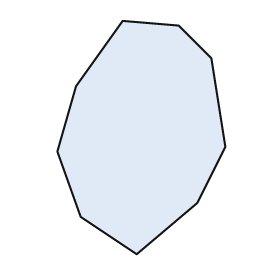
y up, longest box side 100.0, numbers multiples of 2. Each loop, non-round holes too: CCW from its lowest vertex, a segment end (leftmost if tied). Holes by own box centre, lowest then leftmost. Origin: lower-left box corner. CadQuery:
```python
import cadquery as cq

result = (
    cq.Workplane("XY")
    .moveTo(34.0, 0.0)
    .lineTo(60.0, 22.0)
    .lineTo(72.0, 46.0)
    .lineTo(66.0, 84.0)
    .lineTo(52.0, 98.0)
    .lineTo(28.0, 100.0)
    .lineTo(8.0, 72.0)
    .lineTo(0.0, 44.0)
    .lineTo(10.0, 16.0)
    .close()
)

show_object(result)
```